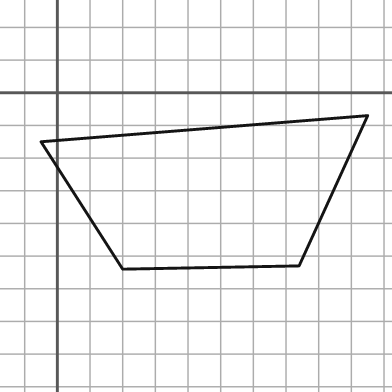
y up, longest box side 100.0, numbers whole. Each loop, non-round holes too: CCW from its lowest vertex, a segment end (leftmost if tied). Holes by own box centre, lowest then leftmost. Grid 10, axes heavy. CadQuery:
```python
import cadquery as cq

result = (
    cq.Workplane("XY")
    .moveTo(20.0, -54.0)
    .lineTo(74.0, -53.0)
    .lineTo(95.0, -7.0)
    .lineTo(-5.0, -15.0)
    .close()
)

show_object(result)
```